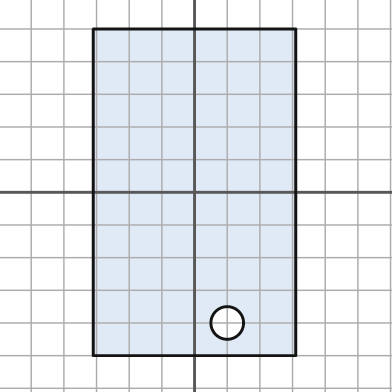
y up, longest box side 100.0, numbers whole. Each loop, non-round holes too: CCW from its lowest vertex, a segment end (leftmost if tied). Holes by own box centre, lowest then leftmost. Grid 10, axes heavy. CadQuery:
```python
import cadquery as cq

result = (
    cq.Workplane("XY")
    .moveTo(-31.0, -50.0)
    .lineTo(31.0, -50.0)
    .lineTo(31.0, 50.0)
    .lineTo(-31.0, 50.0)
    .close()
    .moveTo(10.0, -40.0)
    .circle(5.0)
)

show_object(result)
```